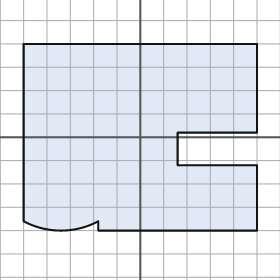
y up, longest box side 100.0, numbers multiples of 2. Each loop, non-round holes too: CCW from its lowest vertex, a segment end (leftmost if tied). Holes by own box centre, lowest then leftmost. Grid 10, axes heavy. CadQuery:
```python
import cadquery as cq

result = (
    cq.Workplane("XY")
    .moveTo(-18.0, -40.0)
    .lineTo(50.0, -40.0)
    .lineTo(50.0, -12.0)
    .lineTo(16.0, -12.0)
    .lineTo(16.0, 2.0)
    .lineTo(50.0, 2.0)
    .lineTo(50.0, 40.0)
    .lineTo(-50.0, 40.0)
    .lineTo(-50.0, -36.0)
    .threePointArc((-34.0, -40.0), (-18.0, -36.0))
    .close()
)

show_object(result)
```